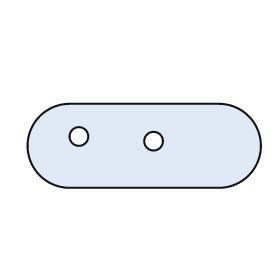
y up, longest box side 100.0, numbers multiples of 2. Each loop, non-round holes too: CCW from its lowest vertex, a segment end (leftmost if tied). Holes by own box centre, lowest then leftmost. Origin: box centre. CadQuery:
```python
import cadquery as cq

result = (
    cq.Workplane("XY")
    .moveTo(-32.0, -18.0)
    .lineTo(32.0, -18.0)
    .threePointArc((50.0, 0.0), (32.0, 18.0))
    .lineTo(-32.0, 18.0)
    .threePointArc((-50.0, 0.0), (-32.0, -18.0))
    .close()
    .moveTo(4.0, 2.0)
    .circle(4.0)
    .moveTo(-28.0, 4.0)
    .circle(4.0)
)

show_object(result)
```